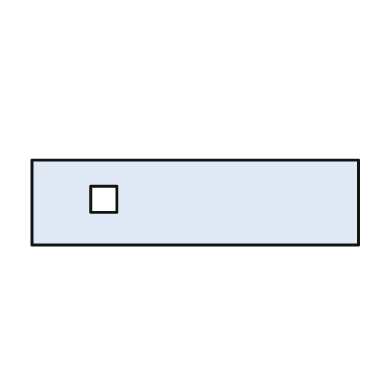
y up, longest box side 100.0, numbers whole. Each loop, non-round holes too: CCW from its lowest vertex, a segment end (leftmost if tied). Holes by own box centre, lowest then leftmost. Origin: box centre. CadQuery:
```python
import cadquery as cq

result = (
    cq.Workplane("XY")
    .moveTo(-50.0, -13.0)
    .lineTo(50.0, -13.0)
    .lineTo(50.0, 13.0)
    .lineTo(-50.0, 13.0)
    .close()
    .moveTo(-32.0, -3.0)
    .lineTo(-24.0, -3.0)
    .lineTo(-24.0, 5.0)
    .lineTo(-32.0, 5.0)
    .close()
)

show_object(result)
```